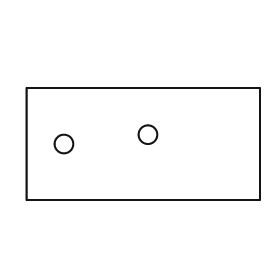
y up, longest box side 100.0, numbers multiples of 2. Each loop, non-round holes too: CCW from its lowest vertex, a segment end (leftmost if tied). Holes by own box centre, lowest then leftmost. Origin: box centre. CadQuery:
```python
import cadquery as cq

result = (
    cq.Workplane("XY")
    .moveTo(-50.0, -24.0)
    .lineTo(50.0, -24.0)
    .lineTo(50.0, 24.0)
    .lineTo(-50.0, 24.0)
    .close()
    .moveTo(-34.0, 0.0)
    .circle(4.0)
    .moveTo(2.0, 4.0)
    .circle(4.0)
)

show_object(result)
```